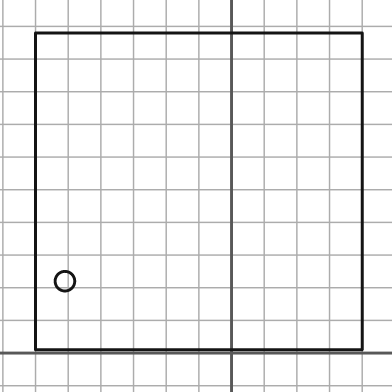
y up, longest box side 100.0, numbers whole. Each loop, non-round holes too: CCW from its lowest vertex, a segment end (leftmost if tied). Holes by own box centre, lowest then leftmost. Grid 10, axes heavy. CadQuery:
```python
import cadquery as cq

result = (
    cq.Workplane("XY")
    .moveTo(-60.0, 1.0)
    .lineTo(40.0, 1.0)
    .lineTo(40.0, 98.0)
    .lineTo(-60.0, 98.0)
    .close()
    .moveTo(-51.0, 22.0)
    .circle(3.0)
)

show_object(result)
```